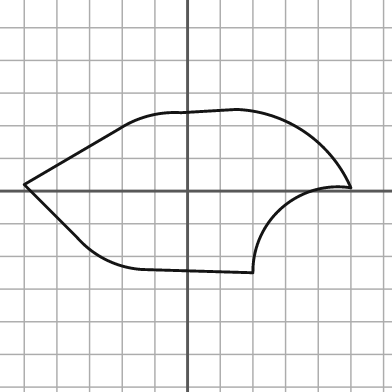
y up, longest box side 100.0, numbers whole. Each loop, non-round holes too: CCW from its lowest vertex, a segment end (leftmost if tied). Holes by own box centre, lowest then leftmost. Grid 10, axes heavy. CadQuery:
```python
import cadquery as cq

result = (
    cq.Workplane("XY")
    .moveTo(20.0, -25.0)
    .threePointArc((29.0, -5.0), (50.0, 1.0))
    .threePointArc((36.0, 18.0), (15.0, 25.0))
    .lineTo(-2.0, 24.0)
    .threePointArc((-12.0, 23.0), (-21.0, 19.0))
    .lineTo(-50.0, 2.0)
    .lineTo(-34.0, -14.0)
    .threePointArc((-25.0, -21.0), (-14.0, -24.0))
    .close()
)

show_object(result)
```